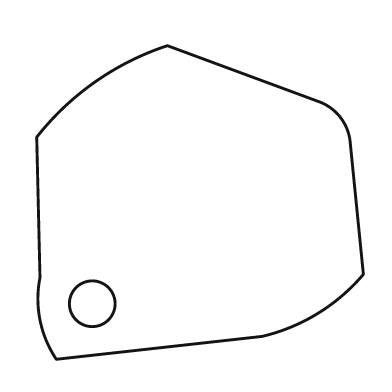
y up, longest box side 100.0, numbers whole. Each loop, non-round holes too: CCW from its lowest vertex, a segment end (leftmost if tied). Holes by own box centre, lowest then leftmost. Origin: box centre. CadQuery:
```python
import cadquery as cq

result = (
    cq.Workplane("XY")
    .moveTo(-44.0, -48.0)
    .lineTo(19.0, -41.0)
    .threePointArc((36.0, -34.0), (50.0, -22.0))
    .lineTo(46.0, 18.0)
    .threePointArc((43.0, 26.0), (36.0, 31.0))
    .lineTo(-10.0, 48.0)
    .threePointArc((-32.0, 37.0), (-50.0, 20.0))
    .lineTo(-49.0, -23.0)
    .threePointArc((-49.0, -36.0), (-44.0, -48.0))
    .close()
    .moveTo(-33.0, -31.0)
    .circle(7.0)
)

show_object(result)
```